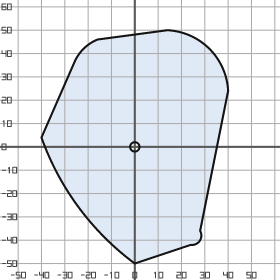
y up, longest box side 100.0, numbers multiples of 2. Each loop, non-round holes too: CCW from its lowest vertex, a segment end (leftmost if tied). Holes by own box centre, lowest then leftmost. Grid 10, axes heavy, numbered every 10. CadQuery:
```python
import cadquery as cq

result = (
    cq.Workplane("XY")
    .moveTo(0.0, -50.0)
    .lineTo(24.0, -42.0)
    .threePointArc((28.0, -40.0), (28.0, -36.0))
    .lineTo(40.0, 24.0)
    .threePointArc((32.0, 42.0), (14.0, 50.0))
    .lineTo(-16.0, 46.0)
    .threePointArc((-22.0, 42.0), (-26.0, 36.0))
    .lineTo(-40.0, 4.0)
    .threePointArc((-24.0, -26.0), (0.0, -50.0))
    .close()
    .moveTo(0.0, 0.0)
    .circle(2.0)
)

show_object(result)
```